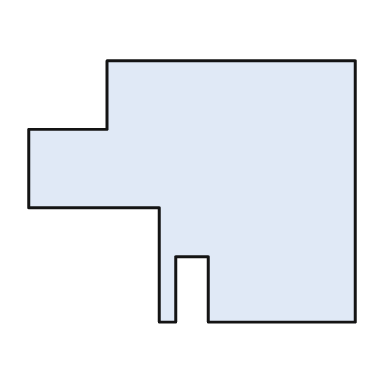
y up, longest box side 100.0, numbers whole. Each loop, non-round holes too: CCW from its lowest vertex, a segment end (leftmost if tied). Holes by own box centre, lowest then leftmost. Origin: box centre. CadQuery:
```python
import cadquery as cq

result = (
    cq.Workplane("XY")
    .moveTo(-10.0, -40.0)
    .lineTo(-5.0, -40.0)
    .lineTo(-5.0, -20.0)
    .lineTo(5.0, -20.0)
    .lineTo(5.0, -40.0)
    .lineTo(50.0, -40.0)
    .lineTo(50.0, 40.0)
    .lineTo(-26.0, 40.0)
    .lineTo(-26.0, 19.0)
    .lineTo(-50.0, 19.0)
    .lineTo(-50.0, -5.0)
    .lineTo(-10.0, -5.0)
    .close()
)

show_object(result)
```